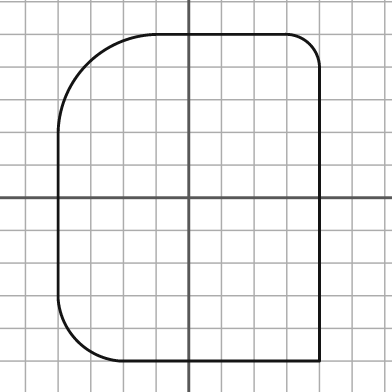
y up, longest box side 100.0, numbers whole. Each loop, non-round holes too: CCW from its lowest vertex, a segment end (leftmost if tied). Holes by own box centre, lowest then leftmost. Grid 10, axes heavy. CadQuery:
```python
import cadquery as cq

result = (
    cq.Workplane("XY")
    .moveTo(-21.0, -50.0)
    .lineTo(40.0, -50.0)
    .lineTo(40.0, 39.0)
    .threePointArc((37.0, 47.0), (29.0, 50.0))
    .lineTo(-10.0, 50.0)
    .threePointArc((-31.0, 41.0), (-40.0, 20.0))
    .lineTo(-40.0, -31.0)
    .threePointArc((-34.0, -44.0), (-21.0, -50.0))
    .close()
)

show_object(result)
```